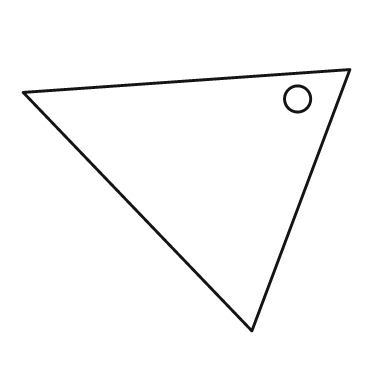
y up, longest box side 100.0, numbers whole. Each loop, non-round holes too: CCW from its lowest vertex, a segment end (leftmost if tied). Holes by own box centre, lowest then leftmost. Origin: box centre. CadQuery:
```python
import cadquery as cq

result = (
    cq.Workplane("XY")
    .moveTo(20.0, -40.0)
    .lineTo(50.0, 40.0)
    .lineTo(-50.0, 33.0)
    .close()
    .moveTo(34.0, 31.0)
    .circle(4.0)
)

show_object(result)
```